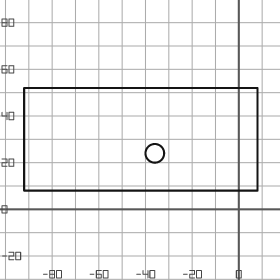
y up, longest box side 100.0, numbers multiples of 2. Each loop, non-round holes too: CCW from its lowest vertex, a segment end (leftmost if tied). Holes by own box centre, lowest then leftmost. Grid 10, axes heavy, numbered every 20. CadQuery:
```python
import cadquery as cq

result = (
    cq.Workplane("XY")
    .moveTo(-92.0, 8.0)
    .lineTo(8.0, 8.0)
    .lineTo(8.0, 52.0)
    .lineTo(-92.0, 52.0)
    .close()
    .moveTo(-36.0, 24.0)
    .circle(4.0)
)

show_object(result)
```